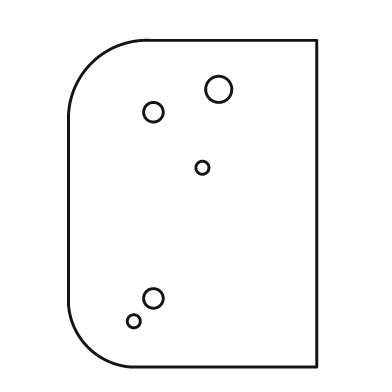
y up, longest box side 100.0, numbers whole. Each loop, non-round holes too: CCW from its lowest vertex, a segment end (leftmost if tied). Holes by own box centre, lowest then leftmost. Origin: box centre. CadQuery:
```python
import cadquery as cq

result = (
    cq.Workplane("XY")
    .moveTo(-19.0, -50.0)
    .lineTo(38.0, -50.0)
    .lineTo(38.0, 50.0)
    .lineTo(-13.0, 50.0)
    .threePointArc((-31.0, 43.0), (-38.0, 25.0))
    .lineTo(-38.0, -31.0)
    .threePointArc((-32.0, -44.0), (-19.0, -50.0))
    .close()
    .moveTo(-18.0, -36.0)
    .circle(2.0)
    .moveTo(-12.0, -29.0)
    .circle(3.0)
    .moveTo(3.0, 11.0)
    .circle(2.0)
    .moveTo(-12.0, 28.0)
    .circle(3.0)
    .moveTo(8.0, 35.0)
    .circle(4.0)
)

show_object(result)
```